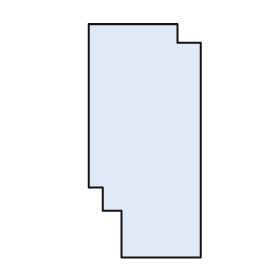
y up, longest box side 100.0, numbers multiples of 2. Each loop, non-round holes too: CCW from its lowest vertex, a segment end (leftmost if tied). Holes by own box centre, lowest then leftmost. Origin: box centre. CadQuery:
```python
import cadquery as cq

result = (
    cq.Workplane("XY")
    .moveTo(-10.0, -50.0)
    .lineTo(24.0, -50.0)
    .lineTo(24.0, 42.0)
    .lineTo(14.0, 42.0)
    .lineTo(14.0, 50.0)
    .lineTo(-24.0, 50.0)
    .lineTo(-24.0, -20.0)
    .lineTo(-18.0, -20.0)
    .lineTo(-18.0, -30.0)
    .lineTo(-10.0, -30.0)
    .close()
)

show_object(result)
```